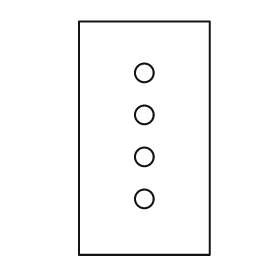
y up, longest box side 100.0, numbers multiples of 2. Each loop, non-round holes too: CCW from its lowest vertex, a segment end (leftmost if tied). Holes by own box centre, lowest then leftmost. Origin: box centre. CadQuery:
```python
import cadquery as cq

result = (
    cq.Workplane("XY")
    .moveTo(-28.0, -50.0)
    .lineTo(28.0, -50.0)
    .lineTo(28.0, 50.0)
    .lineTo(-28.0, 50.0)
    .close()
    .moveTo(0.0, -26.0)
    .circle(4.0)
    .moveTo(0.0, -8.0)
    .circle(4.0)
    .moveTo(0.0, 10.0)
    .circle(4.0)
    .moveTo(0.0, 28.0)
    .circle(4.0)
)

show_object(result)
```